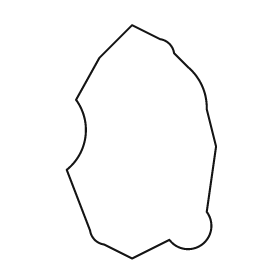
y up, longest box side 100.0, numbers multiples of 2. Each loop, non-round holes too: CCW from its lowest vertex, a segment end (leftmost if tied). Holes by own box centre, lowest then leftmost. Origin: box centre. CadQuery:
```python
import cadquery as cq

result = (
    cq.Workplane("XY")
    .moveTo(-4.0, -50.0)
    .lineTo(12.0, -42.0)
    .threePointArc((26.0, -44.0), (28.0, -30.0))
    .lineTo(32.0, -2.0)
    .lineTo(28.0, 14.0)
    .threePointArc((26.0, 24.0), (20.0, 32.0))
    .lineTo(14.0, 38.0)
    .threePointArc((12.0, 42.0), (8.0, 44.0))
    .lineTo(-4.0, 50.0)
    .lineTo(-18.0, 36.0)
    .lineTo(-28.0, 18.0)
    .threePointArc((-24.0, 2.0), (-32.0, -12.0))
    .lineTo(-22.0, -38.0)
    .threePointArc((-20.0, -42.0), (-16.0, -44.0))
    .close()
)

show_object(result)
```